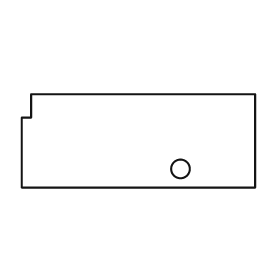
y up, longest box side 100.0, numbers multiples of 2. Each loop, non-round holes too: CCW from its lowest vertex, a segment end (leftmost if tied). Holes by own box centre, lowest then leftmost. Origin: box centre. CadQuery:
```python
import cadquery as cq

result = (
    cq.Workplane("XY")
    .moveTo(-50.0, -20.0)
    .lineTo(50.0, -20.0)
    .lineTo(50.0, 20.0)
    .lineTo(-46.0, 20.0)
    .lineTo(-46.0, 10.0)
    .lineTo(-50.0, 10.0)
    .close()
    .moveTo(18.0, -12.0)
    .circle(4.0)
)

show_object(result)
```